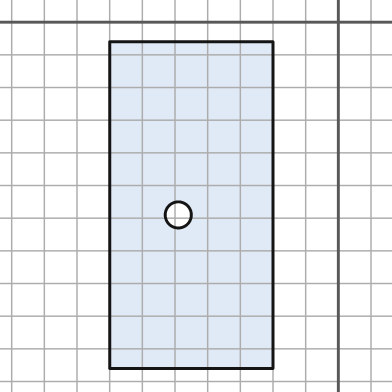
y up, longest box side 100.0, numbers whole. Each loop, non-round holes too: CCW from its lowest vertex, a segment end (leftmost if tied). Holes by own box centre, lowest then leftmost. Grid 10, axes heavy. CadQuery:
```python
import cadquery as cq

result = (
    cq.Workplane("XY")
    .moveTo(-70.0, -106.0)
    .lineTo(-20.0, -106.0)
    .lineTo(-20.0, -6.0)
    .lineTo(-70.0, -6.0)
    .close()
    .moveTo(-49.0, -59.0)
    .circle(4.0)
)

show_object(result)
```